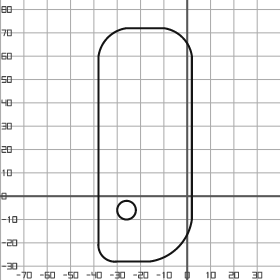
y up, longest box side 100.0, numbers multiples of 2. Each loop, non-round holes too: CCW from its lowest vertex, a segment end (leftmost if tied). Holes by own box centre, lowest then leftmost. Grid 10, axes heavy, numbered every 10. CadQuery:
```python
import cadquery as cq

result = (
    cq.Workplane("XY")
    .moveTo(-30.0, -28.0)
    .lineTo(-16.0, -28.0)
    .threePointArc((-4.0, -22.0), (2.0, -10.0))
    .lineTo(2.0, 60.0)
    .threePointArc((-2.0, 68.0), (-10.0, 72.0))
    .lineTo(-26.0, 72.0)
    .threePointArc((-34.0, 68.0), (-38.0, 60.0))
    .lineTo(-38.0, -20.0)
    .threePointArc((-36.0, -26.0), (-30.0, -28.0))
    .close()
    .moveTo(-26.0, -6.0)
    .circle(4.0)
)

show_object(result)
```